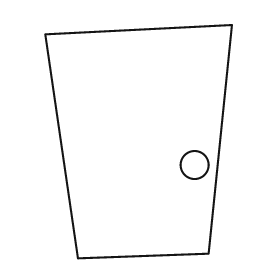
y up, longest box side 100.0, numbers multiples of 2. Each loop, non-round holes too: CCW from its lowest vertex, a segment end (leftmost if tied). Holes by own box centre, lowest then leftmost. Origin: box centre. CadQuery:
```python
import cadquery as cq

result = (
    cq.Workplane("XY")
    .moveTo(-26.0, -50.0)
    .lineTo(30.0, -48.0)
    .lineTo(40.0, 50.0)
    .lineTo(-40.0, 46.0)
    .close()
    .moveTo(24.0, -10.0)
    .circle(6.0)
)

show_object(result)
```